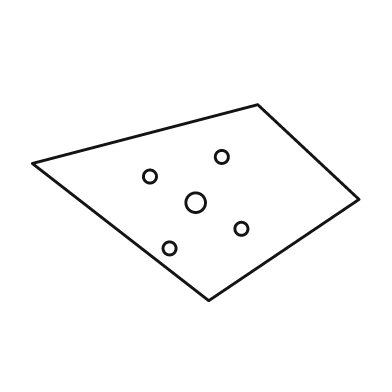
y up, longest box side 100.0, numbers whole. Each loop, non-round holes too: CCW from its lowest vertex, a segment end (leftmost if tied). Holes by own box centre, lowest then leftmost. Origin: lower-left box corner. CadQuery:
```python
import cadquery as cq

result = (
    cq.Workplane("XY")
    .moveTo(54.0, 0.0)
    .lineTo(100.0, 31.0)
    .lineTo(69.0, 60.0)
    .lineTo(0.0, 42.0)
    .close()
    .moveTo(42.0, 16.0)
    .circle(2.0)
    .moveTo(64.0, 22.0)
    .circle(2.0)
    .moveTo(50.0, 30.0)
    .circle(3.0)
    .moveTo(36.0, 38.0)
    .circle(2.0)
    .moveTo(58.0, 44.0)
    .circle(2.0)
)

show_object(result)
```